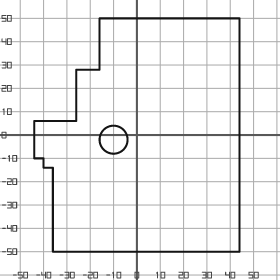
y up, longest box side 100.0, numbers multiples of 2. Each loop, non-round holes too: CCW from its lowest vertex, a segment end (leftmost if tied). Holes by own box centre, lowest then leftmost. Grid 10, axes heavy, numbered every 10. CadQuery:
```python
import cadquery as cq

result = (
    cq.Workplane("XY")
    .moveTo(-36.0, -50.0)
    .lineTo(44.0, -50.0)
    .lineTo(44.0, 50.0)
    .lineTo(-16.0, 50.0)
    .lineTo(-16.0, 28.0)
    .lineTo(-26.0, 28.0)
    .lineTo(-26.0, 6.0)
    .lineTo(-44.0, 6.0)
    .lineTo(-44.0, -10.0)
    .lineTo(-40.0, -10.0)
    .lineTo(-40.0, -14.0)
    .lineTo(-36.0, -14.0)
    .close()
    .moveTo(-10.0, -2.0)
    .circle(6.0)
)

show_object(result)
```